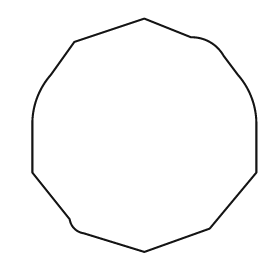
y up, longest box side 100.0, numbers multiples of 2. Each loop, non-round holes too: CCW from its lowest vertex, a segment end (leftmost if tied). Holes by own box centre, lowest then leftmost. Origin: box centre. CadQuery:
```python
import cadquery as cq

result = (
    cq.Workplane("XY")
    .moveTo(0.0, -50.0)
    .lineTo(28.0, -40.0)
    .lineTo(48.0, -16.0)
    .lineTo(48.0, 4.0)
    .threePointArc((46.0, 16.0), (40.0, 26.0))
    .lineTo(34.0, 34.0)
    .threePointArc((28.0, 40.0), (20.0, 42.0))
    .lineTo(0.0, 50.0)
    .lineTo(-30.0, 40.0)
    .lineTo(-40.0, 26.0)
    .threePointArc((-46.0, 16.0), (-48.0, 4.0))
    .lineTo(-48.0, -16.0)
    .lineTo(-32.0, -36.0)
    .threePointArc((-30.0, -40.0), (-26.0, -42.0))
    .close()
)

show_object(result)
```